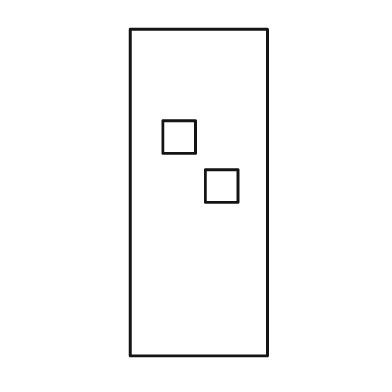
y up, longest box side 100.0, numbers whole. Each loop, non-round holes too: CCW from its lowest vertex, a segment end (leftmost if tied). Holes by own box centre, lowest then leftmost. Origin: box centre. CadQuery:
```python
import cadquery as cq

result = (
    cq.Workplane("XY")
    .moveTo(-21.0, -50.0)
    .lineTo(21.0, -50.0)
    .lineTo(21.0, 50.0)
    .lineTo(-21.0, 50.0)
    .close()
    .moveTo(2.0, -3.0)
    .lineTo(12.0, -3.0)
    .lineTo(12.0, 7.0)
    .lineTo(2.0, 7.0)
    .close()
    .moveTo(-11.0, 12.0)
    .lineTo(-1.0, 12.0)
    .lineTo(-1.0, 22.0)
    .lineTo(-11.0, 22.0)
    .close()
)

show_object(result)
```